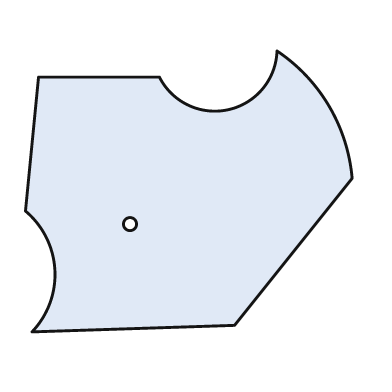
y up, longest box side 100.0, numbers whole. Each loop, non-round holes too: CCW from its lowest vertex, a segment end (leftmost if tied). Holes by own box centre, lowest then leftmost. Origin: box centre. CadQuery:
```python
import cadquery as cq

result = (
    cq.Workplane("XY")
    .moveTo(-48.0, -43.0)
    .lineTo(14.0, -41.0)
    .lineTo(50.0, 4.0)
    .threePointArc((43.0, 26.0), (27.0, 43.0))
    .threePointArc((12.0, 25.0), (-9.0, 35.0))
    .lineTo(-46.0, 35.0)
    .lineTo(-50.0, -6.0)
    .threePointArc((-41.0, -24.0), (-48.0, -43.0))
    .close()
    .moveTo(-18.0, -10.0)
    .circle(2.0)
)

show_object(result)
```